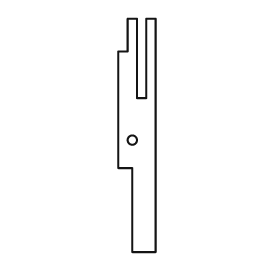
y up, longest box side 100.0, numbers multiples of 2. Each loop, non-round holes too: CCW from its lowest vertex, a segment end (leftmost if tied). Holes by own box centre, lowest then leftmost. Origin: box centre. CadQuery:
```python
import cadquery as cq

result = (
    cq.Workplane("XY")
    .moveTo(-2.0, -50.0)
    .lineTo(8.0, -50.0)
    .lineTo(8.0, 50.0)
    .lineTo(4.0, 50.0)
    .lineTo(4.0, 16.0)
    .lineTo(0.0, 16.0)
    .lineTo(0.0, 50.0)
    .lineTo(-4.0, 50.0)
    .lineTo(-4.0, 36.0)
    .lineTo(-8.0, 36.0)
    .lineTo(-8.0, -14.0)
    .lineTo(-2.0, -14.0)
    .close()
    .moveTo(-2.0, -2.0)
    .circle(2.0)
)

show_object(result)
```